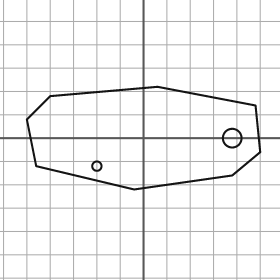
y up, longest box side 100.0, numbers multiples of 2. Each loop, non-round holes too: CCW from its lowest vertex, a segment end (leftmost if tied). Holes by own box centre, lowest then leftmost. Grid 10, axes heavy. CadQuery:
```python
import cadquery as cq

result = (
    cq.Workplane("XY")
    .moveTo(-4.0, -22.0)
    .lineTo(38.0, -16.0)
    .lineTo(50.0, -6.0)
    .lineTo(48.0, 14.0)
    .lineTo(6.0, 22.0)
    .lineTo(-40.0, 18.0)
    .lineTo(-50.0, 8.0)
    .lineTo(-46.0, -12.0)
    .close()
    .moveTo(-20.0, -12.0)
    .circle(2.0)
    .moveTo(38.0, 0.0)
    .circle(4.0)
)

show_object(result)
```